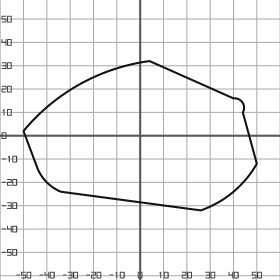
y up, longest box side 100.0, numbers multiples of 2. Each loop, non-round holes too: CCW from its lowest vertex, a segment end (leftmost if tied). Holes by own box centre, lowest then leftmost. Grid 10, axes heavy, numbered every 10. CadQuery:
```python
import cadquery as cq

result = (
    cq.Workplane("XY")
    .moveTo(26.0, -32.0)
    .threePointArc((40.0, -24.0), (50.0, -12.0))
    .lineTo(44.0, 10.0)
    .threePointArc((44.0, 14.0), (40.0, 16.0))
    .lineTo(4.0, 32.0)
    .threePointArc((-26.0, 22.0), (-50.0, 2.0))
    .lineTo(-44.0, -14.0)
    .threePointArc((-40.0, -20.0), (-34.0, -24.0))
    .close()
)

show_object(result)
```